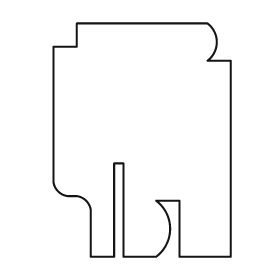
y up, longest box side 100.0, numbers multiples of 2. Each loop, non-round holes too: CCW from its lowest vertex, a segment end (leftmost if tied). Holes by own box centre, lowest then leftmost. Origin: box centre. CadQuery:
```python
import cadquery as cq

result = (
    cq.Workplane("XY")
    .moveTo(-22.0, -50.0)
    .lineTo(-12.0, -50.0)
    .lineTo(-12.0, -10.0)
    .lineTo(-8.0, -10.0)
    .lineTo(-8.0, -50.0)
    .lineTo(6.0, -50.0)
    .threePointArc((12.0, -38.0), (6.0, -26.0))
    .lineTo(16.0, -26.0)
    .lineTo(16.0, -50.0)
    .lineTo(38.0, -50.0)
    .lineTo(38.0, 34.0)
    .lineTo(28.0, 34.0)
    .threePointArc((32.0, 42.0), (28.0, 50.0))
    .lineTo(-28.0, 50.0)
    .lineTo(-28.0, 40.0)
    .lineTo(-38.0, 40.0)
    .lineTo(-38.0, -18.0)
    .threePointArc((-36.0, -22.0), (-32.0, -24.0))
    .lineTo(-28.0, -24.0)
    .threePointArc((-24.0, -26.0), (-22.0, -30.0))
    .close()
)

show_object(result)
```